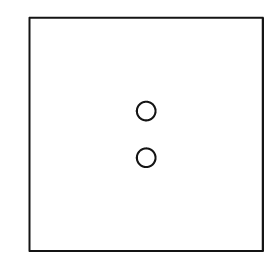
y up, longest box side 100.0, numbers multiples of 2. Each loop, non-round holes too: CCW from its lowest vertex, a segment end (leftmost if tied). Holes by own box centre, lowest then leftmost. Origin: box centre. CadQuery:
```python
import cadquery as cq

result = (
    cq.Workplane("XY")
    .moveTo(-50.0, -50.0)
    .lineTo(50.0, -50.0)
    .lineTo(50.0, 50.0)
    .lineTo(-50.0, 50.0)
    .close()
    .moveTo(0.0, -10.0)
    .circle(4.0)
    .moveTo(0.0, 10.0)
    .circle(4.0)
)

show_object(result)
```